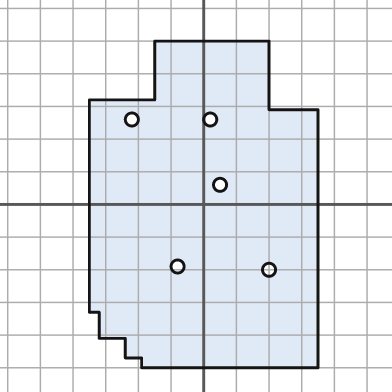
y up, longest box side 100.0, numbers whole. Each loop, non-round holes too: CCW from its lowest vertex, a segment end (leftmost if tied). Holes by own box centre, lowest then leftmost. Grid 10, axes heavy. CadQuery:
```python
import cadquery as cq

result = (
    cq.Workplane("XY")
    .moveTo(-19.0, -50.0)
    .lineTo(35.0, -50.0)
    .lineTo(35.0, 29.0)
    .lineTo(20.0, 29.0)
    .lineTo(20.0, 50.0)
    .lineTo(-15.0, 50.0)
    .lineTo(-15.0, 32.0)
    .lineTo(-35.0, 32.0)
    .lineTo(-35.0, -33.0)
    .lineTo(-32.0, -33.0)
    .lineTo(-32.0, -41.0)
    .lineTo(-24.0, -41.0)
    .lineTo(-24.0, -47.0)
    .lineTo(-19.0, -47.0)
    .close()
    .moveTo(20.0, -20.0)
    .circle(2.0)
    .moveTo(-8.0, -19.0)
    .circle(2.0)
    .moveTo(5.0, 6.0)
    .circle(2.0)
    .moveTo(-22.0, 26.0)
    .circle(2.0)
    .moveTo(2.0, 26.0)
    .circle(2.0)
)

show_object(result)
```